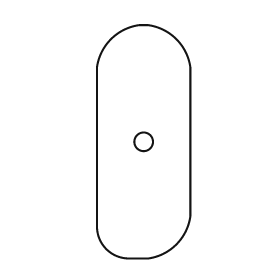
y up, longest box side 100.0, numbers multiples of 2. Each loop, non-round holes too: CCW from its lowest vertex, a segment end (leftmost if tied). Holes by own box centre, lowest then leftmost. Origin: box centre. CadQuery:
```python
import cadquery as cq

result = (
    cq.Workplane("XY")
    .moveTo(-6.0, -50.0)
    .lineTo(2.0, -50.0)
    .threePointArc((14.0, -44.0), (20.0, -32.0))
    .lineTo(20.0, 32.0)
    .threePointArc((14.0, 44.0), (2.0, 50.0))
    .lineTo(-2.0, 50.0)
    .threePointArc((-14.0, 44.0), (-20.0, 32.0))
    .lineTo(-20.0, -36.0)
    .threePointArc((-16.0, -46.0), (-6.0, -50.0))
    .close()
    .moveTo(0.0, 0.0)
    .circle(4.0)
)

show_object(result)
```